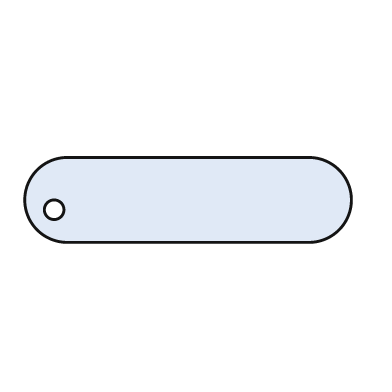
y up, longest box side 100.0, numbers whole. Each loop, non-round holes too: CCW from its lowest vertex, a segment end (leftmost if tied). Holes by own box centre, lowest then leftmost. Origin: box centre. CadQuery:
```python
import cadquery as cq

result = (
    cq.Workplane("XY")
    .moveTo(-37.0, -13.0)
    .lineTo(37.0, -13.0)
    .threePointArc((50.0, 0.0), (37.0, 13.0))
    .lineTo(-37.0, 13.0)
    .threePointArc((-50.0, 0.0), (-37.0, -13.0))
    .close()
    .moveTo(-41.0, -3.0)
    .circle(3.0)
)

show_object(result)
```